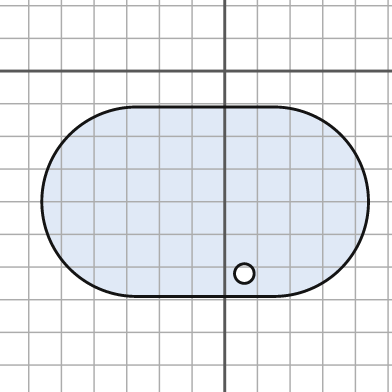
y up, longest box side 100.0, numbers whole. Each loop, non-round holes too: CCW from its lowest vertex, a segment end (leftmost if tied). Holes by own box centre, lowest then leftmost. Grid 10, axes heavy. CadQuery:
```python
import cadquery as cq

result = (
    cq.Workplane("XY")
    .moveTo(-27.0, -69.0)
    .lineTo(15.0, -69.0)
    .threePointArc((44.0, -40.0), (15.0, -11.0))
    .lineTo(-27.0, -11.0)
    .threePointArc((-56.0, -40.0), (-27.0, -69.0))
    .close()
    .moveTo(6.0, -62.0)
    .circle(3.0)
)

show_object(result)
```